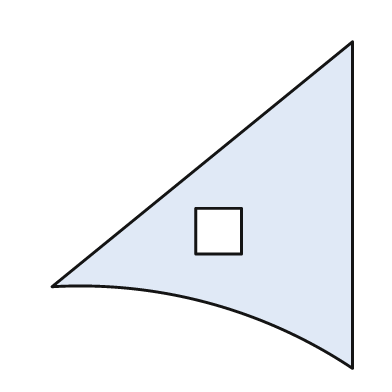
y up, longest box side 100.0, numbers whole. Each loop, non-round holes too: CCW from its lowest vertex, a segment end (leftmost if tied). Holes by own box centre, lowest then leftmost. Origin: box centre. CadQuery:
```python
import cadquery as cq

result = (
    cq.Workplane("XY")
    .moveTo(46.0, -50.0)
    .lineTo(46.0, 50.0)
    .lineTo(-46.0, -25.0)
    .threePointArc((2.0, -30.0), (46.0, -50.0))
    .close()
    .moveTo(-2.0, -15.0)
    .lineTo(12.0, -15.0)
    .lineTo(12.0, -1.0)
    .lineTo(-2.0, -1.0)
    .close()
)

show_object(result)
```